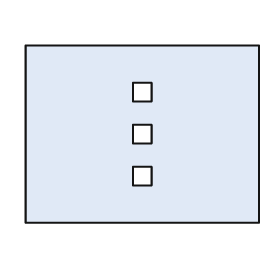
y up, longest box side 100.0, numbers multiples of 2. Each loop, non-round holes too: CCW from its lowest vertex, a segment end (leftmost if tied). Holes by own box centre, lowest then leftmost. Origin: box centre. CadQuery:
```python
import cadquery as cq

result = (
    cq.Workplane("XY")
    .moveTo(-50.0, -38.0)
    .lineTo(50.0, -38.0)
    .lineTo(50.0, 38.0)
    .lineTo(-50.0, 38.0)
    .close()
    .moveTo(-4.0, -22.0)
    .lineTo(4.0, -22.0)
    .lineTo(4.0, -14.0)
    .lineTo(-4.0, -14.0)
    .close()
    .moveTo(-4.0, -4.0)
    .lineTo(4.0, -4.0)
    .lineTo(4.0, 4.0)
    .lineTo(-4.0, 4.0)
    .close()
    .moveTo(-4.0, 14.0)
    .lineTo(4.0, 14.0)
    .lineTo(4.0, 22.0)
    .lineTo(-4.0, 22.0)
    .close()
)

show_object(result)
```